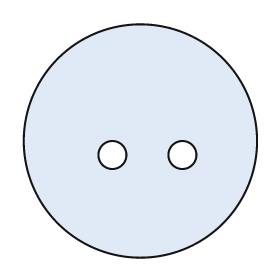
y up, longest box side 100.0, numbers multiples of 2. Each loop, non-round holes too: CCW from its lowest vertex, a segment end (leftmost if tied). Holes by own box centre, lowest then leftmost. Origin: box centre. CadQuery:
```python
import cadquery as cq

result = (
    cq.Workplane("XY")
    .moveTo(0.0, 0.0)
    .circle(50.0)
    .moveTo(-12.0, -6.0)
    .circle(6.0)
    .moveTo(18.0, -6.0)
    .circle(6.0)
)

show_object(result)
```